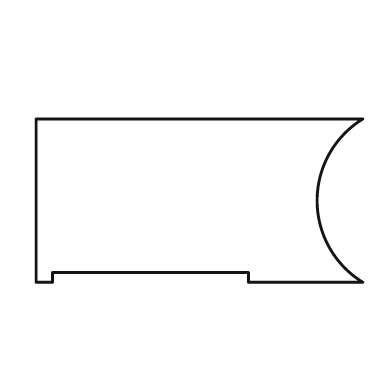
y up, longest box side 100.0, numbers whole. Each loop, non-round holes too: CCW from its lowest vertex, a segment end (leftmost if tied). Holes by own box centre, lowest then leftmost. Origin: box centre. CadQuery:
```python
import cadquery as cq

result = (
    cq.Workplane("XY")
    .moveTo(-50.0, -25.0)
    .lineTo(-45.0, -25.0)
    .lineTo(-45.0, -22.0)
    .lineTo(15.0, -22.0)
    .lineTo(15.0, -25.0)
    .lineTo(50.0, -25.0)
    .threePointArc((36.0, 0.0), (50.0, 25.0))
    .lineTo(-50.0, 25.0)
    .close()
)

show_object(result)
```